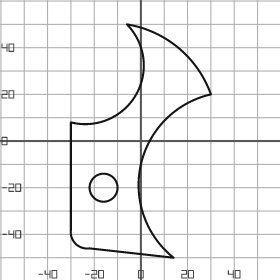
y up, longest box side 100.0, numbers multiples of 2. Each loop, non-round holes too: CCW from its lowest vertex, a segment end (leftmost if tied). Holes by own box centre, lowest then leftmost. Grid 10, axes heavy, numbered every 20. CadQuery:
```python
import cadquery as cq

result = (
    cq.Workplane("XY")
    .moveTo(14.0, -50.0)
    .threePointArc((0.0, -10.0), (30.0, 20.0))
    .threePointArc((16.0, 40.0), (-6.0, 50.0))
    .threePointArc((-2.0, 20.0), (-30.0, 8.0))
    .lineTo(-30.0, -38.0)
    .threePointArc((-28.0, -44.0), (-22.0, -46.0))
    .close()
    .moveTo(-16.0, -20.0)
    .circle(6.0)
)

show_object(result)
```